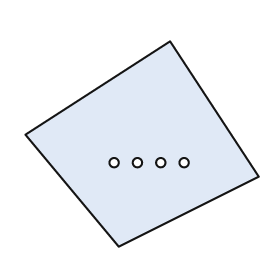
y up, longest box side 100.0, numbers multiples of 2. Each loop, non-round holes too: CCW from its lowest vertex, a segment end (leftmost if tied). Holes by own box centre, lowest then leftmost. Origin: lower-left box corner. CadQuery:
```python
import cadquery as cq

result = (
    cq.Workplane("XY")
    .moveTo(40.0, 0.0)
    .lineTo(100.0, 30.0)
    .lineTo(62.0, 88.0)
    .lineTo(0.0, 48.0)
    .close()
    .moveTo(38.0, 36.0)
    .circle(2.0)
    .moveTo(48.0, 36.0)
    .circle(2.0)
    .moveTo(58.0, 36.0)
    .circle(2.0)
    .moveTo(68.0, 36.0)
    .circle(2.0)
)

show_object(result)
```